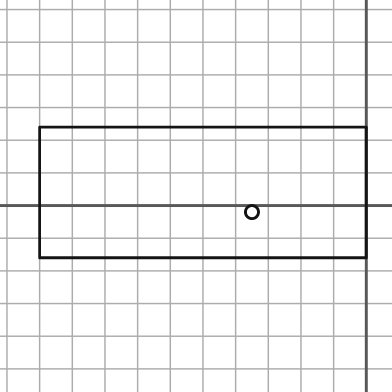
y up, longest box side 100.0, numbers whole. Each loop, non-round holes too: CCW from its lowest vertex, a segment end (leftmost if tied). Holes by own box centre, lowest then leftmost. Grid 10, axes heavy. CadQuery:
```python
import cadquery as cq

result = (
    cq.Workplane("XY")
    .moveTo(-100.0, -16.0)
    .lineTo(0.0, -16.0)
    .lineTo(0.0, 24.0)
    .lineTo(-100.0, 24.0)
    .close()
    .moveTo(-35.0, -2.0)
    .circle(2.0)
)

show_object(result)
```